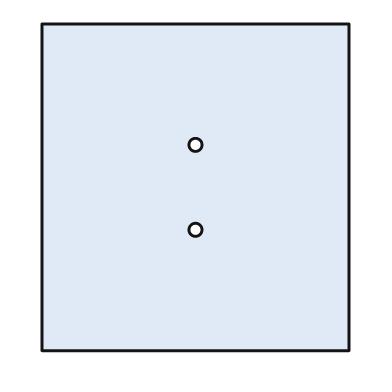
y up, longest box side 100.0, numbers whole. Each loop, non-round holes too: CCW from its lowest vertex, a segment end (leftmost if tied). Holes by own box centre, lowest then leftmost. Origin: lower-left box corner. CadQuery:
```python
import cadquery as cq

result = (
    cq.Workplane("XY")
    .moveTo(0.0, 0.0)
    .lineTo(94.0, 0.0)
    .lineTo(94.0, 100.0)
    .lineTo(0.0, 100.0)
    .close()
    .moveTo(47.0, 37.0)
    .circle(2.0)
    .moveTo(47.0, 63.0)
    .circle(2.0)
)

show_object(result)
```